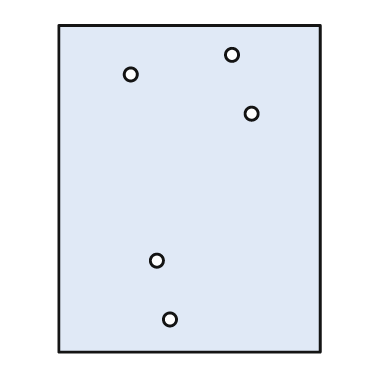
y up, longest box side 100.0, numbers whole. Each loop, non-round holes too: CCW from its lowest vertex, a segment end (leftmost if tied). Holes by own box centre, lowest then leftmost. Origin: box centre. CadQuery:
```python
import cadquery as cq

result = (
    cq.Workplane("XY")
    .moveTo(-40.0, -50.0)
    .lineTo(40.0, -50.0)
    .lineTo(40.0, 50.0)
    .lineTo(-40.0, 50.0)
    .close()
    .moveTo(-6.0, -40.0)
    .circle(2.0)
    .moveTo(-10.0, -22.0)
    .circle(2.0)
    .moveTo(19.0, 23.0)
    .circle(2.0)
    .moveTo(-18.0, 35.0)
    .circle(2.0)
    .moveTo(13.0, 41.0)
    .circle(2.0)
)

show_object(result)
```